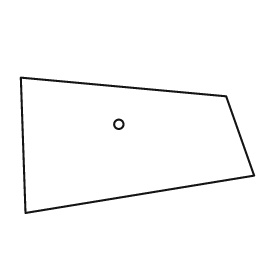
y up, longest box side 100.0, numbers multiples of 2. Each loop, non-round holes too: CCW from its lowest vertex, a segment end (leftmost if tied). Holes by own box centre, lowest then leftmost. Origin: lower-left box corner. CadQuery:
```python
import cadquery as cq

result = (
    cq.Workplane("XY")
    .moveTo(2.0, 0.0)
    .lineTo(100.0, 16.0)
    .lineTo(88.0, 50.0)
    .lineTo(0.0, 58.0)
    .close()
    .moveTo(42.0, 38.0)
    .circle(2.0)
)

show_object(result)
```